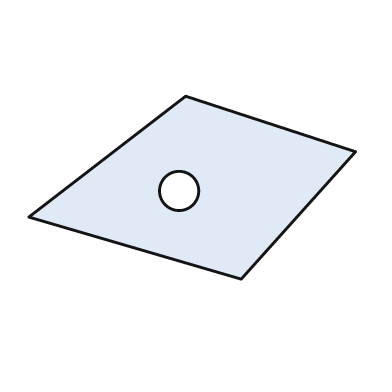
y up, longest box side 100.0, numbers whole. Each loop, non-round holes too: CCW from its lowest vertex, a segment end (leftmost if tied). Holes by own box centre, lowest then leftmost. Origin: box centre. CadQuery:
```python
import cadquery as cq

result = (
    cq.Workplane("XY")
    .moveTo(15.0, -28.0)
    .lineTo(50.0, 11.0)
    .lineTo(-2.0, 28.0)
    .lineTo(-50.0, -9.0)
    .close()
    .moveTo(-4.0, -1.0)
    .circle(6.0)
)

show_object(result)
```